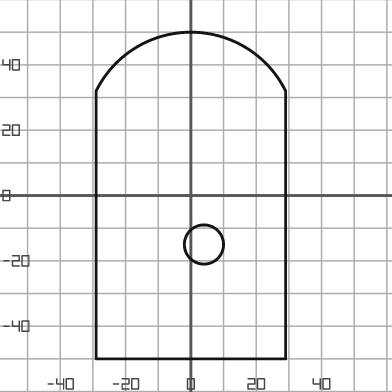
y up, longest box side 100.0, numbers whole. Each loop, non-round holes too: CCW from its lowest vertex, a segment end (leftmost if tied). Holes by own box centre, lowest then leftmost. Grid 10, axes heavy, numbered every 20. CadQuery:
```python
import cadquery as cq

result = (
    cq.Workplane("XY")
    .moveTo(-29.0, -50.0)
    .lineTo(29.0, -50.0)
    .lineTo(29.0, 32.0)
    .threePointArc((0.0, 50.0), (-29.0, 32.0))
    .close()
    .moveTo(4.0, -15.0)
    .circle(6.0)
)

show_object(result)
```